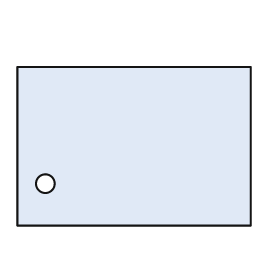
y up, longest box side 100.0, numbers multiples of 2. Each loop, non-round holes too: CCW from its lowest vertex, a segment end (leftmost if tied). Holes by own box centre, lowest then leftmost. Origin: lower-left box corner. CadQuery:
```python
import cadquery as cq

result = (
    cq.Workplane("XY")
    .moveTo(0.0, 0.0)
    .lineTo(100.0, 0.0)
    .lineTo(100.0, 68.0)
    .lineTo(0.0, 68.0)
    .close()
    .moveTo(12.0, 18.0)
    .circle(4.0)
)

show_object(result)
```